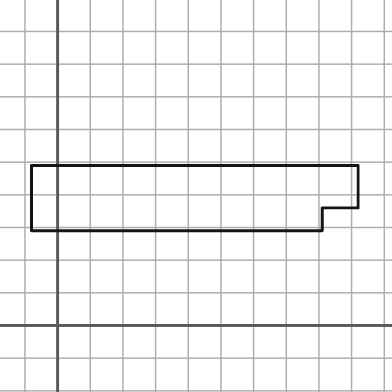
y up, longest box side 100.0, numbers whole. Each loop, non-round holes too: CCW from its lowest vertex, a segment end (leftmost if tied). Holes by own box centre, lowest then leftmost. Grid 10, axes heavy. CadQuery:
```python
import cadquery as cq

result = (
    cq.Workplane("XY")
    .moveTo(-8.0, 29.0)
    .lineTo(81.0, 29.0)
    .lineTo(81.0, 36.0)
    .lineTo(92.0, 36.0)
    .lineTo(92.0, 49.0)
    .lineTo(-8.0, 49.0)
    .close()
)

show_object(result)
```